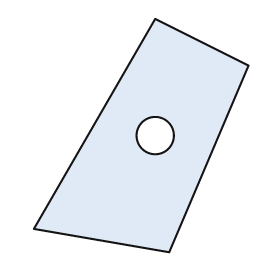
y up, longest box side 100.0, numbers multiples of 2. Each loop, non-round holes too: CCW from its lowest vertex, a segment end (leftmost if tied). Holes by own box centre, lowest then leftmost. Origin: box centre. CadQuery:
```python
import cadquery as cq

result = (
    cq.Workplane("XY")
    .moveTo(12.0, -50.0)
    .lineTo(46.0, 30.0)
    .lineTo(6.0, 50.0)
    .lineTo(-46.0, -40.0)
    .close()
    .moveTo(6.0, 0.0)
    .circle(8.0)
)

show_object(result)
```